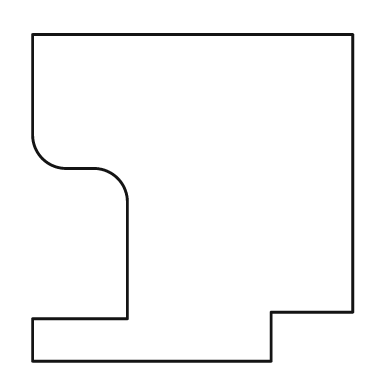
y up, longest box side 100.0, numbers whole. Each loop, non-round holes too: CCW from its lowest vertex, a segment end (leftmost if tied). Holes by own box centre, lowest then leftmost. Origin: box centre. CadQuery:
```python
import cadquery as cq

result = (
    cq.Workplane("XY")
    .moveTo(-49.0, -50.0)
    .lineTo(24.0, -50.0)
    .lineTo(24.0, -35.0)
    .lineTo(49.0, -35.0)
    .lineTo(49.0, 50.0)
    .lineTo(-49.0, 50.0)
    .lineTo(-49.0, 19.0)
    .threePointArc((-46.0, 12.0), (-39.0, 9.0))
    .lineTo(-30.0, 9.0)
    .threePointArc((-23.0, 6.0), (-20.0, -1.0))
    .lineTo(-20.0, -37.0)
    .lineTo(-49.0, -37.0)
    .close()
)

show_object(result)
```